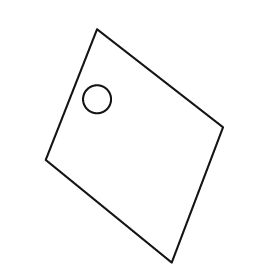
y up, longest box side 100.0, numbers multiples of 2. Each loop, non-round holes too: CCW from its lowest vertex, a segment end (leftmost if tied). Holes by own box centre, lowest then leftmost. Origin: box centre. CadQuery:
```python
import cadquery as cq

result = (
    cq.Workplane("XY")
    .moveTo(16.0, -50.0)
    .lineTo(38.0, 8.0)
    .lineTo(-16.0, 50.0)
    .lineTo(-38.0, -6.0)
    .close()
    .moveTo(-16.0, 20.0)
    .circle(6.0)
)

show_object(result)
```